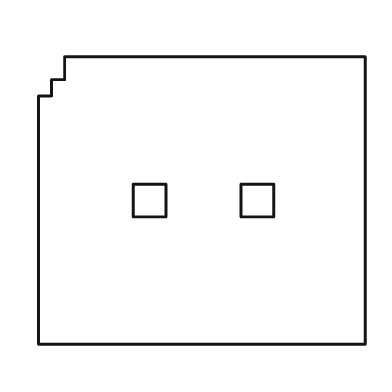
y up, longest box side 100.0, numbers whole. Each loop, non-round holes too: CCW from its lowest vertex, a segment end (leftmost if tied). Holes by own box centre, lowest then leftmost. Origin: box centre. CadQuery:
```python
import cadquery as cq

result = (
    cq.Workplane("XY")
    .moveTo(-50.0, -44.0)
    .lineTo(50.0, -44.0)
    .lineTo(50.0, 44.0)
    .lineTo(-42.0, 44.0)
    .lineTo(-42.0, 37.0)
    .lineTo(-46.0, 37.0)
    .lineTo(-46.0, 32.0)
    .lineTo(-50.0, 32.0)
    .close()
    .moveTo(-21.0, -5.0)
    .lineTo(-11.0, -5.0)
    .lineTo(-11.0, 5.0)
    .lineTo(-21.0, 5.0)
    .close()
    .moveTo(12.0, -5.0)
    .lineTo(22.0, -5.0)
    .lineTo(22.0, 5.0)
    .lineTo(12.0, 5.0)
    .close()
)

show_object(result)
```